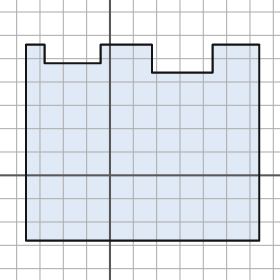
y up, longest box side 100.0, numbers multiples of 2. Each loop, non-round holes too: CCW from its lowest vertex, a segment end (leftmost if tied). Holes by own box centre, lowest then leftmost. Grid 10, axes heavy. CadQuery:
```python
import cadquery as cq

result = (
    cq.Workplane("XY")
    .moveTo(-36.0, -28.0)
    .lineTo(64.0, -28.0)
    .lineTo(64.0, 56.0)
    .lineTo(44.0, 56.0)
    .lineTo(44.0, 44.0)
    .lineTo(18.0, 44.0)
    .lineTo(18.0, 56.0)
    .lineTo(-4.0, 56.0)
    .lineTo(-4.0, 48.0)
    .lineTo(-28.0, 48.0)
    .lineTo(-28.0, 56.0)
    .lineTo(-36.0, 56.0)
    .close()
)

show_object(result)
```